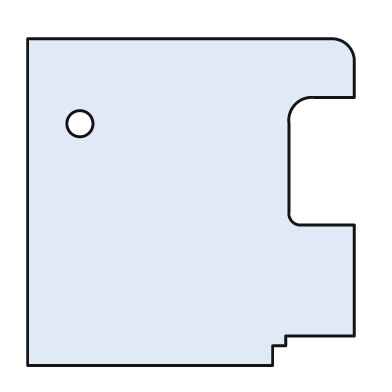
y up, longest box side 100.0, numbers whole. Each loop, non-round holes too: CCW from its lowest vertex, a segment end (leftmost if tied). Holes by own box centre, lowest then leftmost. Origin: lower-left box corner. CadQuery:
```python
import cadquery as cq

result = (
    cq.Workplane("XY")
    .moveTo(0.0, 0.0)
    .lineTo(75.0, 0.0)
    .lineTo(75.0, 6.0)
    .lineTo(79.0, 6.0)
    .lineTo(79.0, 9.0)
    .lineTo(100.0, 9.0)
    .lineTo(100.0, 43.0)
    .lineTo(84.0, 43.0)
    .threePointArc((81.0, 44.0), (80.0, 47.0))
    .lineTo(80.0, 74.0)
    .threePointArc((82.0, 80.0), (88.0, 82.0))
    .lineTo(100.0, 82.0)
    .lineTo(100.0, 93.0)
    .threePointArc((98.0, 98.0), (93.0, 100.0))
    .lineTo(0.0, 100.0)
    .close()
    .moveTo(16.0, 74.0)
    .circle(4.0)
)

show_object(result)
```